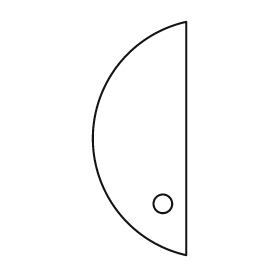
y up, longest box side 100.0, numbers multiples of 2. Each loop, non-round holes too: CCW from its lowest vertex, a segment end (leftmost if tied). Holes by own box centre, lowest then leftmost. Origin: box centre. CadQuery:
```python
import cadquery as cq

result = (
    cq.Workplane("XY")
    .moveTo(20.0, -50.0)
    .lineTo(20.0, 50.0)
    .threePointArc((-20.0, 0.0), (20.0, -50.0))
    .close()
    .moveTo(10.0, -28.0)
    .circle(4.0)
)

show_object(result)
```